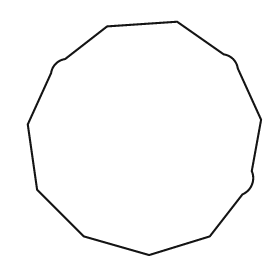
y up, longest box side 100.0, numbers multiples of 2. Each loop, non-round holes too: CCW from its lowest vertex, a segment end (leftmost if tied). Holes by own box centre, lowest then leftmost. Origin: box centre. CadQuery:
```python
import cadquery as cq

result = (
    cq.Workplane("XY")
    .moveTo(2.0, -50.0)
    .lineTo(28.0, -42.0)
    .lineTo(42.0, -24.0)
    .threePointArc((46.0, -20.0), (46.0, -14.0))
    .lineTo(50.0, 8.0)
    .lineTo(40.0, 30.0)
    .threePointArc((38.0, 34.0), (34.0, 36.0))
    .lineTo(14.0, 50.0)
    .lineTo(-16.0, 48.0)
    .lineTo(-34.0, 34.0)
    .threePointArc((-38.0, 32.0), (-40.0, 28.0))
    .lineTo(-50.0, 6.0)
    .lineTo(-46.0, -22.0)
    .lineTo(-26.0, -42.0)
    .close()
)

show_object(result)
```